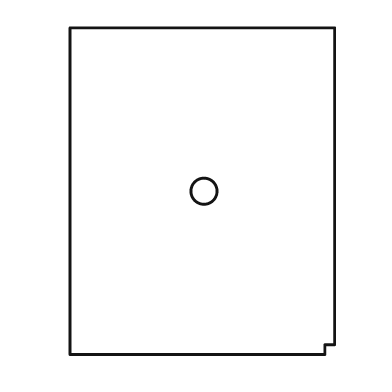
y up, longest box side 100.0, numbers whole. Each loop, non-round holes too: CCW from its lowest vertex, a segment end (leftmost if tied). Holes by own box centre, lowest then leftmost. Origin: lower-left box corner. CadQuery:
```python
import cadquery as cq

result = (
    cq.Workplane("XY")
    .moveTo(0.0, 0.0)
    .lineTo(78.0, 0.0)
    .lineTo(78.0, 3.0)
    .lineTo(81.0, 3.0)
    .lineTo(81.0, 100.0)
    .lineTo(0.0, 100.0)
    .close()
    .moveTo(41.0, 50.0)
    .circle(4.0)
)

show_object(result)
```